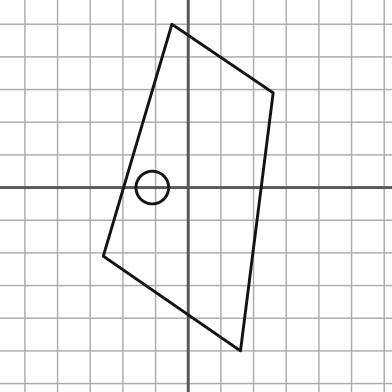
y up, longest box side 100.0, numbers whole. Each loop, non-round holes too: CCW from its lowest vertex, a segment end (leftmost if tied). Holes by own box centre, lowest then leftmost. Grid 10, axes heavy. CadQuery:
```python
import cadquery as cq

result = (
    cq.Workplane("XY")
    .moveTo(16.0, -50.0)
    .lineTo(26.0, 29.0)
    .lineTo(-5.0, 50.0)
    .lineTo(-26.0, -21.0)
    .close()
    .moveTo(-11.0, 0.0)
    .circle(5.0)
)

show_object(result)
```